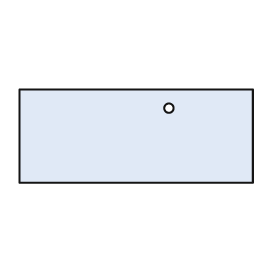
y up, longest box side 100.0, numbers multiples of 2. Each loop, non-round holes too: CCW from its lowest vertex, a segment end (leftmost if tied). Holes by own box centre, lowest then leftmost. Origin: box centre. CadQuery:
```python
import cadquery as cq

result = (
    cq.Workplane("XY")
    .moveTo(-50.0, -20.0)
    .lineTo(50.0, -20.0)
    .lineTo(50.0, 20.0)
    .lineTo(-50.0, 20.0)
    .close()
    .moveTo(14.0, 12.0)
    .circle(2.0)
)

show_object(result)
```